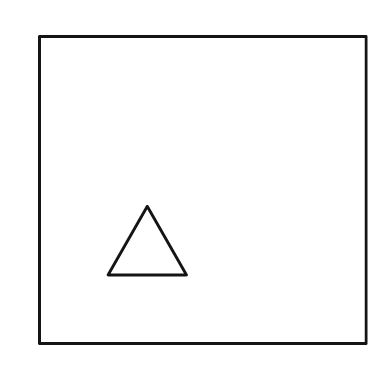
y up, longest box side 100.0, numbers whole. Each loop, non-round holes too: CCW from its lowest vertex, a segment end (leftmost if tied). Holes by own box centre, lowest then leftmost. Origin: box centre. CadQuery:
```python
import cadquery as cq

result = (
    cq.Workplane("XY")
    .moveTo(-50.0, -47.0)
    .lineTo(50.0, -47.0)
    .lineTo(50.0, 47.0)
    .lineTo(-50.0, 47.0)
    .close()
    .moveTo(-29.0, -26.0)
    .lineTo(-5.0, -26.0)
    .lineTo(-17.0, -5.0)
    .close()
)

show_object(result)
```